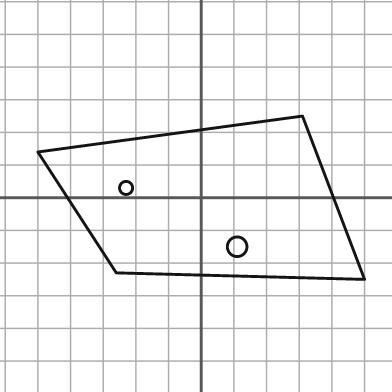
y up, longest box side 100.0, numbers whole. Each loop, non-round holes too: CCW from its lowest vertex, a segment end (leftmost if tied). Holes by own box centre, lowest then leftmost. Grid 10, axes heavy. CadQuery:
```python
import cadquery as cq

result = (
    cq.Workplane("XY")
    .moveTo(50.0, -25.0)
    .lineTo(31.0, 25.0)
    .lineTo(-50.0, 14.0)
    .lineTo(-26.0, -23.0)
    .close()
    .moveTo(11.0, -15.0)
    .circle(3.0)
    .moveTo(-23.0, 3.0)
    .circle(2.0)
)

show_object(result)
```